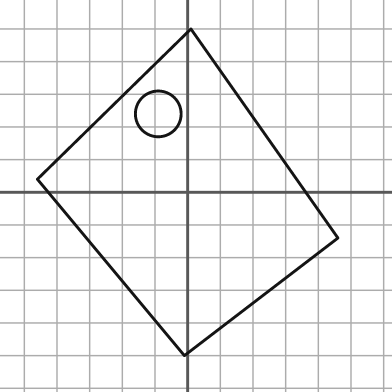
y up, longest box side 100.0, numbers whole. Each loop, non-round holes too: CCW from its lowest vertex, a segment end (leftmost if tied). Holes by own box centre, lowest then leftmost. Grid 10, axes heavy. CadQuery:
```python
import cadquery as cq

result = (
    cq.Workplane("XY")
    .moveTo(-1.0, -50.0)
    .lineTo(46.0, -14.0)
    .lineTo(1.0, 50.0)
    .lineTo(-46.0, 4.0)
    .close()
    .moveTo(-9.0, 24.0)
    .circle(7.0)
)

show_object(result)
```